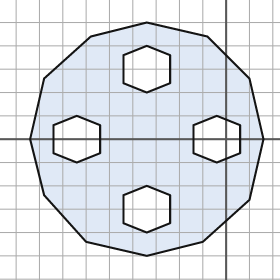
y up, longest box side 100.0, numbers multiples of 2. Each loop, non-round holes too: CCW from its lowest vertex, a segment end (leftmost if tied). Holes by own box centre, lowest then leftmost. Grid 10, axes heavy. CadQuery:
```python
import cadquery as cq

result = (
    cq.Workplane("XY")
    .moveTo(-34.0, -50.0)
    .lineTo(-10.0, -44.0)
    .lineTo(10.0, -26.0)
    .lineTo(16.0, 0.0)
    .lineTo(10.0, 26.0)
    .lineTo(-8.0, 44.0)
    .lineTo(-34.0, 50.0)
    .lineTo(-58.0, 44.0)
    .lineTo(-78.0, 26.0)
    .lineTo(-84.0, 0.0)
    .lineTo(-78.0, -24.0)
    .lineTo(-60.0, -44.0)
    .close()
    .moveTo(-34.0, -40.0)
    .lineTo(-24.0, -36.0)
    .lineTo(-24.0, -24.0)
    .lineTo(-34.0, -20.0)
    .lineTo(-44.0, -24.0)
    .lineTo(-44.0, -36.0)
    .close()
    .moveTo(-64.0, -10.0)
    .lineTo(-54.0, -6.0)
    .lineTo(-54.0, 6.0)
    .lineTo(-64.0, 10.0)
    .lineTo(-74.0, 6.0)
    .lineTo(-74.0, -6.0)
    .close()
    .moveTo(-4.0, -10.0)
    .lineTo(6.0, -6.0)
    .lineTo(6.0, 6.0)
    .lineTo(-4.0, 10.0)
    .lineTo(-14.0, 6.0)
    .lineTo(-14.0, -6.0)
    .close()
    .moveTo(-34.0, 20.0)
    .lineTo(-24.0, 24.0)
    .lineTo(-24.0, 36.0)
    .lineTo(-34.0, 40.0)
    .lineTo(-44.0, 36.0)
    .lineTo(-44.0, 24.0)
    .close()
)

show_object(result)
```